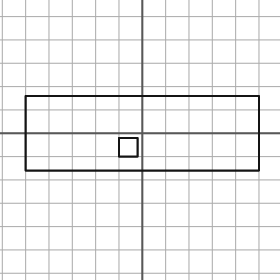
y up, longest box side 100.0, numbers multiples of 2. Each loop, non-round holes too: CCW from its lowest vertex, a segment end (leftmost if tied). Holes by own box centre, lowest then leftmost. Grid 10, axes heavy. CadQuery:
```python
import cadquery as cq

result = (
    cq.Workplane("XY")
    .moveTo(-50.0, -16.0)
    .lineTo(50.0, -16.0)
    .lineTo(50.0, 16.0)
    .lineTo(-50.0, 16.0)
    .close()
    .moveTo(-10.0, -10.0)
    .lineTo(-2.0, -10.0)
    .lineTo(-2.0, -2.0)
    .lineTo(-10.0, -2.0)
    .close()
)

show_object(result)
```